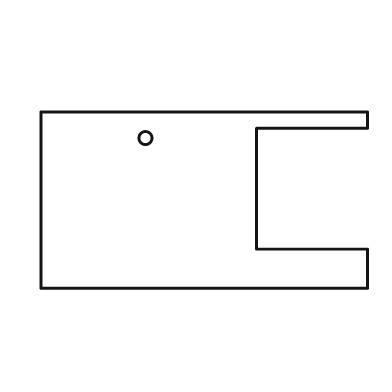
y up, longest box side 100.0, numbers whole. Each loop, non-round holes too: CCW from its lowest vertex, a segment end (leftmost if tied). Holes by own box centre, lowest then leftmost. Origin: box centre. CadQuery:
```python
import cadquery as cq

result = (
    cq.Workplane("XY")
    .moveTo(-50.0, -27.0)
    .lineTo(50.0, -27.0)
    .lineTo(50.0, -15.0)
    .lineTo(16.0, -15.0)
    .lineTo(16.0, 22.0)
    .lineTo(50.0, 22.0)
    .lineTo(50.0, 27.0)
    .lineTo(-50.0, 27.0)
    .close()
    .moveTo(-18.0, 19.0)
    .circle(2.0)
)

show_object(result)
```